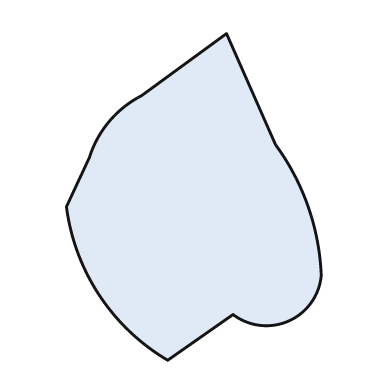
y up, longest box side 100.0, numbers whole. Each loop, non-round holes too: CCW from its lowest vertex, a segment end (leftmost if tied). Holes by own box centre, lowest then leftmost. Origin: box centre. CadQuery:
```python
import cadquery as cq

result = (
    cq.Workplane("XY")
    .moveTo(-8.0, -50.0)
    .lineTo(12.0, -36.0)
    .threePointArc((29.0, -38.0), (39.0, -24.0))
    .threePointArc((35.0, -3.0), (25.0, 16.0))
    .lineTo(10.0, 50.0)
    .lineTo(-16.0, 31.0)
    .threePointArc((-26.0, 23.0), (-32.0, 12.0))
    .lineTo(-39.0, -3.0)
    .threePointArc((-29.0, -30.0), (-8.0, -50.0))
    .close()
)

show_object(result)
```